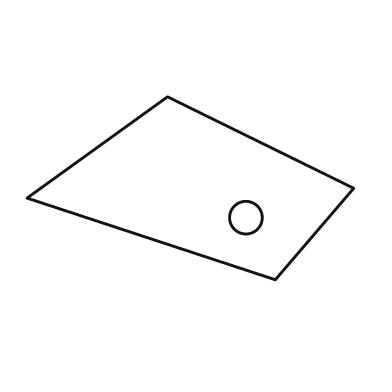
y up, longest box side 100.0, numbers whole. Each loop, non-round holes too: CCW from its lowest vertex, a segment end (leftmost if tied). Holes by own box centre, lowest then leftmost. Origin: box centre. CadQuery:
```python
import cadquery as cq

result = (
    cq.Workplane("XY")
    .moveTo(26.0, -28.0)
    .lineTo(50.0, 0.0)
    .lineTo(-7.0, 28.0)
    .lineTo(-50.0, -3.0)
    .close()
    .moveTo(17.0, -9.0)
    .circle(5.0)
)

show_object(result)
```